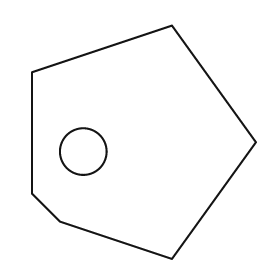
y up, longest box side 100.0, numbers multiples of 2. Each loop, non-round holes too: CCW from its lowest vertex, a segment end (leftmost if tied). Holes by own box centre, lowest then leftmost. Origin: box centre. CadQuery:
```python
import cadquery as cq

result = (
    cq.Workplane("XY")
    .moveTo(12.0, -50.0)
    .lineTo(48.0, 0.0)
    .lineTo(12.0, 50.0)
    .lineTo(-48.0, 30.0)
    .lineTo(-48.0, -22.0)
    .lineTo(-36.0, -34.0)
    .close()
    .moveTo(-26.0, -4.0)
    .circle(10.0)
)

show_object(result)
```